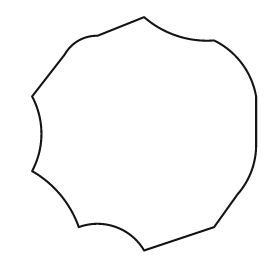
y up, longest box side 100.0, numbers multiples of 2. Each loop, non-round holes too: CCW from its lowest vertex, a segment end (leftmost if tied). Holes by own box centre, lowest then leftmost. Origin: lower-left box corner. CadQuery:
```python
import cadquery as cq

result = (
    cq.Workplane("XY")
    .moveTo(48.0, 0.0)
    .lineTo(78.0, 10.0)
    .lineTo(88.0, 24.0)
    .threePointArc((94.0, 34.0), (96.0, 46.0))
    .lineTo(96.0, 66.0)
    .threePointArc((90.0, 80.0), (78.0, 90.0))
    .threePointArc((62.0, 92.0), (48.0, 100.0))
    .lineTo(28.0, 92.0)
    .threePointArc((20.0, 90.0), (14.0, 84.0))
    .lineTo(0.0, 66.0)
    .threePointArc((4.0, 50.0), (0.0, 34.0))
    .threePointArc((12.0, 24.0), (20.0, 10.0))
    .threePointArc((36.0, 10.0), (48.0, 0.0))
    .close()
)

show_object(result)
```